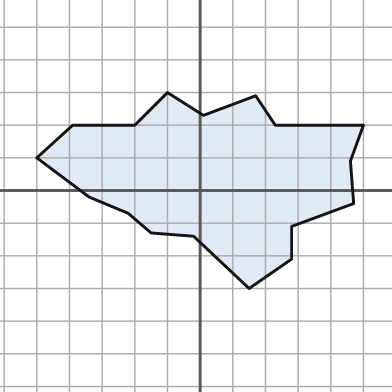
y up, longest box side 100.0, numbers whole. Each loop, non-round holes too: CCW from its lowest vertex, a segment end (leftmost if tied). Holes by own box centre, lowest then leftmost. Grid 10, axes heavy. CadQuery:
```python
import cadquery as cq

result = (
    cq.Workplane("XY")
    .moveTo(15.0, -30.0)
    .lineTo(28.0, -21.0)
    .lineTo(28.0, -11.0)
    .lineTo(47.0, -4.0)
    .lineTo(46.0, 9.0)
    .lineTo(50.0, 20.0)
    .lineTo(23.0, 20.0)
    .lineTo(17.0, 29.0)
    .lineTo(1.0, 23.0)
    .lineTo(-10.0, 30.0)
    .lineTo(-20.0, 20.0)
    .lineTo(-39.0, 20.0)
    .lineTo(-50.0, 10.0)
    .lineTo(-34.0, -2.0)
    .lineTo(-22.0, -7.0)
    .lineTo(-15.0, -13.0)
    .lineTo(-2.0, -14.0)
    .close()
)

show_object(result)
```